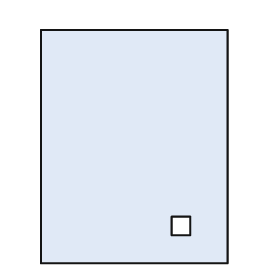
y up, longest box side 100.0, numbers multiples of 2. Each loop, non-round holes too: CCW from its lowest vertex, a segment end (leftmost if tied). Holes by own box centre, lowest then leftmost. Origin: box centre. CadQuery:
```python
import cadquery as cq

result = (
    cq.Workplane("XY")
    .moveTo(-40.0, -50.0)
    .lineTo(40.0, -50.0)
    .lineTo(40.0, 50.0)
    .lineTo(-40.0, 50.0)
    .close()
    .moveTo(16.0, -38.0)
    .lineTo(24.0, -38.0)
    .lineTo(24.0, -30.0)
    .lineTo(16.0, -30.0)
    .close()
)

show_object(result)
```